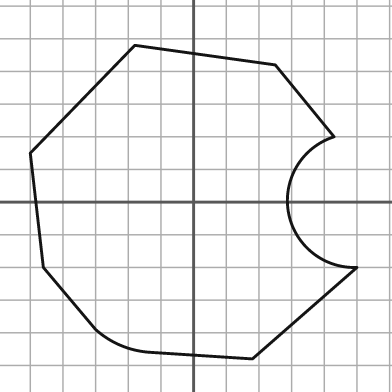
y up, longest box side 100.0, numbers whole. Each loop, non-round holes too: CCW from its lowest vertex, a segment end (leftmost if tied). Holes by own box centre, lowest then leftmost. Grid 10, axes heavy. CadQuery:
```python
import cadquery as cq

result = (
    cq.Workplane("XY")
    .moveTo(18.0, -48.0)
    .lineTo(50.0, -20.0)
    .threePointArc((29.0, -3.0), (43.0, 20.0))
    .lineTo(25.0, 42.0)
    .lineTo(-18.0, 48.0)
    .lineTo(-50.0, 15.0)
    .lineTo(-46.0, -20.0)
    .lineTo(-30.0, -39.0)
    .threePointArc((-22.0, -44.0), (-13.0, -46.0))
    .close()
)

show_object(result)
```